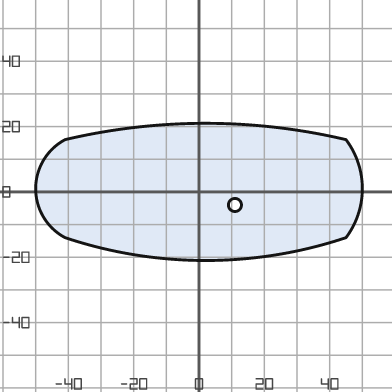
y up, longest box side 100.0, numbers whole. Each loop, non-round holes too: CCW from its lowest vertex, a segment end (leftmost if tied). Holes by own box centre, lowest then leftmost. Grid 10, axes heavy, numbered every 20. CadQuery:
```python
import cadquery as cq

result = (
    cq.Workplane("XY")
    .moveTo(-41.0, -14.0)
    .threePointArc((2.0, -21.0), (45.0, -14.0))
    .threePointArc((50.0, 1.0), (45.0, 16.0))
    .threePointArc((2.0, 21.0), (-41.0, 16.0))
    .threePointArc((-50.0, 1.0), (-41.0, -14.0))
    .close()
    .moveTo(11.0, -4.0)
    .circle(2.0)
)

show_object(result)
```